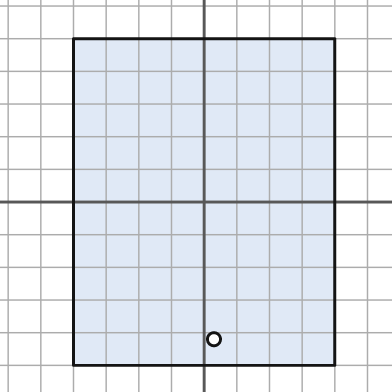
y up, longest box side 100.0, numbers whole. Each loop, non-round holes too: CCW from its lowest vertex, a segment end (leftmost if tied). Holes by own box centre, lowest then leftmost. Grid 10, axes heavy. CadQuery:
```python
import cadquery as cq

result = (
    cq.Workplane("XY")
    .moveTo(-40.0, -50.0)
    .lineTo(40.0, -50.0)
    .lineTo(40.0, 50.0)
    .lineTo(-40.0, 50.0)
    .close()
    .moveTo(3.0, -42.0)
    .circle(2.0)
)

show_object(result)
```